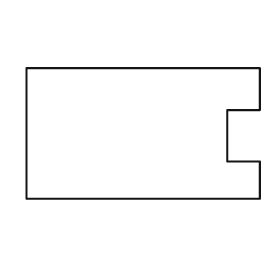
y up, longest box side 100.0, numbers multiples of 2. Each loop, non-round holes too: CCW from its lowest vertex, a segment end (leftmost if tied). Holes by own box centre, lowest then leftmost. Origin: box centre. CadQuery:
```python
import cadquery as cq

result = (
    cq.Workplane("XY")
    .moveTo(-50.0, -28.0)
    .lineTo(50.0, -28.0)
    .lineTo(50.0, -12.0)
    .lineTo(36.0, -12.0)
    .lineTo(36.0, 10.0)
    .lineTo(50.0, 10.0)
    .lineTo(50.0, 28.0)
    .lineTo(-50.0, 28.0)
    .close()
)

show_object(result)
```